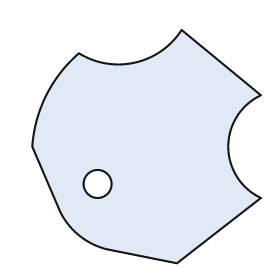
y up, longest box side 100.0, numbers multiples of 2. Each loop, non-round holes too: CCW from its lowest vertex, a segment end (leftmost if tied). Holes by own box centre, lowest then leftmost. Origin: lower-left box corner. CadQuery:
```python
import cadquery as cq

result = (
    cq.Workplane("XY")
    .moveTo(62.0, 0.0)
    .lineTo(98.0, 28.0)
    .threePointArc((84.0, 50.0), (98.0, 72.0))
    .lineTo(64.0, 100.0)
    .threePointArc((44.0, 86.0), (20.0, 90.0))
    .threePointArc((6.0, 72.0), (0.0, 50.0))
    .lineTo(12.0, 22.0)
    .threePointArc((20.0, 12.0), (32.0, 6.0))
    .close()
    .moveTo(28.0, 34.0)
    .circle(6.0)
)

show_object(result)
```